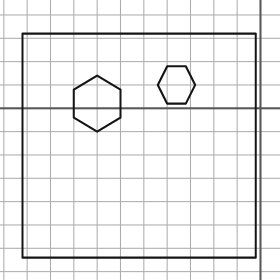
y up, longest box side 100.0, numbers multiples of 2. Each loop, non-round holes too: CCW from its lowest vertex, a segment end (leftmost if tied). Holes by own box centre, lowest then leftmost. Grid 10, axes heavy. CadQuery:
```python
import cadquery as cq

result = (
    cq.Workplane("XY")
    .moveTo(-102.0, -64.0)
    .lineTo(-2.0, -64.0)
    .lineTo(-2.0, 32.0)
    .lineTo(-102.0, 32.0)
    .close()
    .moveTo(-70.0, -10.0)
    .lineTo(-60.0, -4.0)
    .lineTo(-60.0, 8.0)
    .lineTo(-70.0, 14.0)
    .lineTo(-80.0, 8.0)
    .lineTo(-80.0, -4.0)
    .close()
    .moveTo(-40.0, 2.0)
    .lineTo(-32.0, 2.0)
    .lineTo(-28.0, 10.0)
    .lineTo(-32.0, 18.0)
    .lineTo(-40.0, 18.0)
    .lineTo(-44.0, 10.0)
    .close()
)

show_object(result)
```